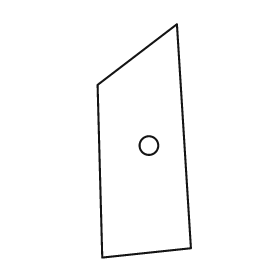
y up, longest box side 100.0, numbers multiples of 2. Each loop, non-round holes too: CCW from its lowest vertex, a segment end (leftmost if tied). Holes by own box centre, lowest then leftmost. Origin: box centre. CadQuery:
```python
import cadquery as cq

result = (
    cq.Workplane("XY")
    .moveTo(-18.0, -50.0)
    .lineTo(20.0, -46.0)
    .lineTo(14.0, 50.0)
    .lineTo(-20.0, 24.0)
    .close()
    .moveTo(2.0, -2.0)
    .circle(4.0)
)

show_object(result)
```